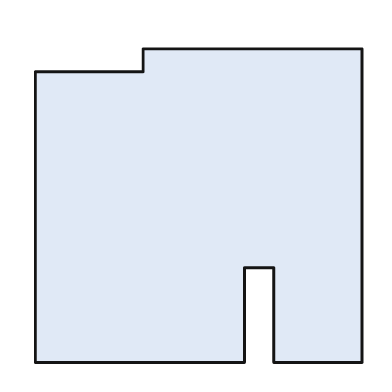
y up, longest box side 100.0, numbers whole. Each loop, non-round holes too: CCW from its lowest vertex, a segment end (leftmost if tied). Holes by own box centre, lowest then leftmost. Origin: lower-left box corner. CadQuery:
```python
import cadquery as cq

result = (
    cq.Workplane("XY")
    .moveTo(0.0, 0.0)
    .lineTo(64.0, 0.0)
    .lineTo(64.0, 29.0)
    .lineTo(73.0, 29.0)
    .lineTo(73.0, 0.0)
    .lineTo(100.0, 0.0)
    .lineTo(100.0, 96.0)
    .lineTo(33.0, 96.0)
    .lineTo(33.0, 89.0)
    .lineTo(0.0, 89.0)
    .close()
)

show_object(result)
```